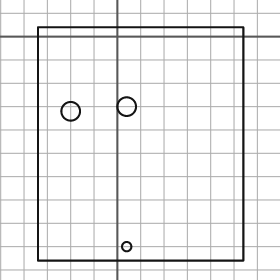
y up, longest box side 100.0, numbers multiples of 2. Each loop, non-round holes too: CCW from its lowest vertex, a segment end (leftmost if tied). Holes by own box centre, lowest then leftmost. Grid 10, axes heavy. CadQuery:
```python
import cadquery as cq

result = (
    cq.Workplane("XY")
    .moveTo(-34.0, -96.0)
    .lineTo(54.0, -96.0)
    .lineTo(54.0, 4.0)
    .lineTo(-34.0, 4.0)
    .close()
    .moveTo(4.0, -90.0)
    .circle(2.0)
    .moveTo(-20.0, -32.0)
    .circle(4.0)
    .moveTo(4.0, -30.0)
    .circle(4.0)
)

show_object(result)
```